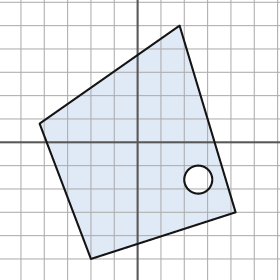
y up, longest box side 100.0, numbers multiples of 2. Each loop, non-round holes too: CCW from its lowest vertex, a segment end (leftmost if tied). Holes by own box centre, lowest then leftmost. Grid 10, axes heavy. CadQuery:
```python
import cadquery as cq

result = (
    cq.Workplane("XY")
    .moveTo(-20.0, -50.0)
    .lineTo(42.0, -30.0)
    .lineTo(18.0, 50.0)
    .lineTo(-42.0, 8.0)
    .close()
    .moveTo(26.0, -16.0)
    .circle(6.0)
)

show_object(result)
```